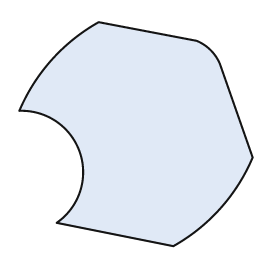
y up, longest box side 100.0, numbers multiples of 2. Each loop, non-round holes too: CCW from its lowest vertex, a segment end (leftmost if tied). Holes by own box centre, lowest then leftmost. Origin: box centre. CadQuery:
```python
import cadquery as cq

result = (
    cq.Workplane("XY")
    .moveTo(16.0, -48.0)
    .threePointArc((36.0, -32.0), (50.0, -10.0))
    .lineTo(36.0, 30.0)
    .threePointArc((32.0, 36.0), (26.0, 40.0))
    .lineTo(-16.0, 48.0)
    .threePointArc((-36.0, 32.0), (-50.0, 10.0))
    .threePointArc((-24.0, -8.0), (-34.0, -38.0))
    .close()
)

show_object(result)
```